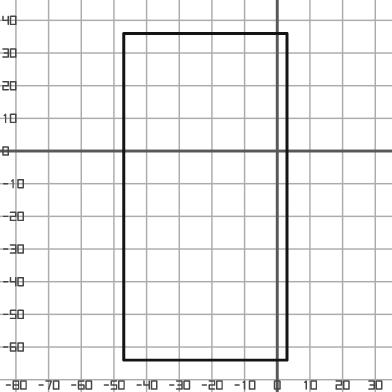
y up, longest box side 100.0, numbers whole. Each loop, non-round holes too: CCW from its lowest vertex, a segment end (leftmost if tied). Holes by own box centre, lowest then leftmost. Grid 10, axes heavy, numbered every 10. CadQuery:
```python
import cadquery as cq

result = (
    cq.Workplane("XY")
    .moveTo(-47.0, -64.0)
    .lineTo(3.0, -64.0)
    .lineTo(3.0, 36.0)
    .lineTo(-47.0, 36.0)
    .close()
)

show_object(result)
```